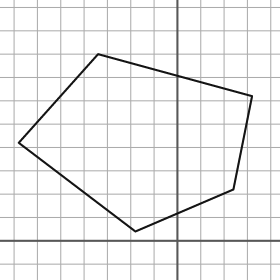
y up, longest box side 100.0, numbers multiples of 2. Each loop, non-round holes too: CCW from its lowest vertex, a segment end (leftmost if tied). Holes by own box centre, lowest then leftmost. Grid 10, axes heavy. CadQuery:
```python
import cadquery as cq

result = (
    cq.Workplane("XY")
    .moveTo(-18.0, 4.0)
    .lineTo(24.0, 22.0)
    .lineTo(32.0, 62.0)
    .lineTo(-34.0, 80.0)
    .lineTo(-68.0, 42.0)
    .close()
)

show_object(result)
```